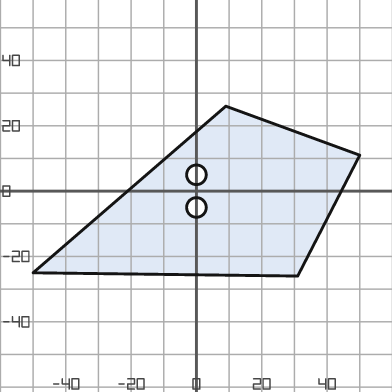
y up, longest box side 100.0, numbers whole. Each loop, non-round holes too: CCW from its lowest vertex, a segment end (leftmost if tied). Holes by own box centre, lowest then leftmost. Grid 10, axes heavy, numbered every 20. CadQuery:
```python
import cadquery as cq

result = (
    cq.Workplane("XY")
    .moveTo(31.0, -26.0)
    .lineTo(50.0, 11.0)
    .lineTo(9.0, 26.0)
    .lineTo(-50.0, -25.0)
    .close()
    .moveTo(0.0, -5.0)
    .circle(3.0)
    .moveTo(0.0, 5.0)
    .circle(3.0)
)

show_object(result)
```